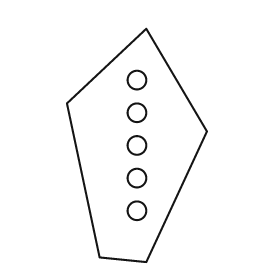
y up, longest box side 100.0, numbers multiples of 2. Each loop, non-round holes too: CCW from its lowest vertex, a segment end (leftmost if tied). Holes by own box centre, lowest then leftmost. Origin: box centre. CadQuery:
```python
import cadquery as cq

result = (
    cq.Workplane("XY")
    .moveTo(4.0, -50.0)
    .lineTo(30.0, 6.0)
    .lineTo(4.0, 50.0)
    .lineTo(-30.0, 18.0)
    .lineTo(-16.0, -48.0)
    .close()
    .moveTo(0.0, -28.0)
    .circle(4.0)
    .moveTo(0.0, -14.0)
    .circle(4.0)
    .moveTo(0.0, 0.0)
    .circle(4.0)
    .moveTo(0.0, 14.0)
    .circle(4.0)
    .moveTo(0.0, 28.0)
    .circle(4.0)
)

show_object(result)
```